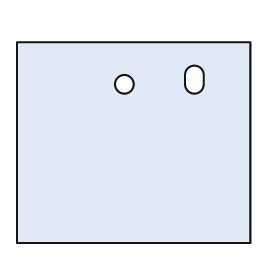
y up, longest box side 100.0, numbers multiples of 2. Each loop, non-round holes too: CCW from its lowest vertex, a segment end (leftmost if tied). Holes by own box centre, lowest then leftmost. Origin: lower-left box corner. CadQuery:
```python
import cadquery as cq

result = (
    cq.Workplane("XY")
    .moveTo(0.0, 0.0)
    .lineTo(100.0, 0.0)
    .lineTo(100.0, 86.0)
    .lineTo(0.0, 86.0)
    .close()
    .moveTo(46.0, 68.0)
    .circle(4.0)
    .moveTo(72.0, 68.0)
    .threePointArc((76.0, 64.0), (80.0, 68.0))
    .lineTo(80.0, 72.0)
    .threePointArc((76.0, 76.0), (72.0, 72.0))
    .close()
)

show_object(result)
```